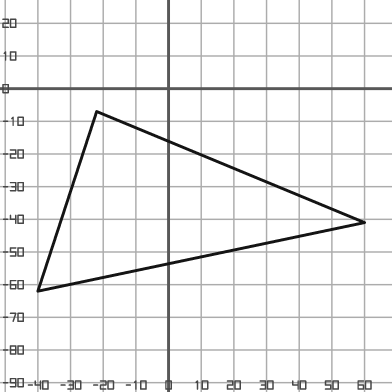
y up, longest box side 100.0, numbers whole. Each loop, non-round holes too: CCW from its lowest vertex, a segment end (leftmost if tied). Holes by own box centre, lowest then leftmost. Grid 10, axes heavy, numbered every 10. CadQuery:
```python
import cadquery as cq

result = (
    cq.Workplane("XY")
    .moveTo(-40.0, -62.0)
    .lineTo(60.0, -41.0)
    .lineTo(-22.0, -7.0)
    .close()
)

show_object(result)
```